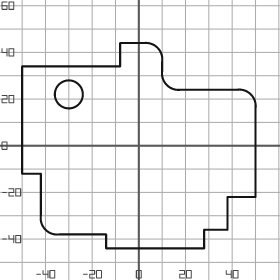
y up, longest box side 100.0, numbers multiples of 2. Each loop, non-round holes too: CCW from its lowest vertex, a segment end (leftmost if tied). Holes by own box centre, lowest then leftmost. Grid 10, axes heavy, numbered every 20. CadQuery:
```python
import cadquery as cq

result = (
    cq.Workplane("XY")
    .moveTo(-14.0, -44.0)
    .lineTo(28.0, -44.0)
    .lineTo(28.0, -36.0)
    .lineTo(38.0, -36.0)
    .lineTo(38.0, -22.0)
    .lineTo(50.0, -22.0)
    .lineTo(50.0, 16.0)
    .threePointArc((48.0, 22.0), (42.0, 24.0))
    .lineTo(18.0, 24.0)
    .threePointArc((12.0, 26.0), (10.0, 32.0))
    .lineTo(10.0, 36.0)
    .threePointArc((8.0, 42.0), (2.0, 44.0))
    .lineTo(-8.0, 44.0)
    .lineTo(-8.0, 34.0)
    .lineTo(-50.0, 34.0)
    .lineTo(-50.0, -12.0)
    .lineTo(-42.0, -12.0)
    .lineTo(-42.0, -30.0)
    .threePointArc((-40.0, -36.0), (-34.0, -38.0))
    .lineTo(-14.0, -38.0)
    .close()
    .moveTo(-30.0, 22.0)
    .circle(6.0)
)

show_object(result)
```